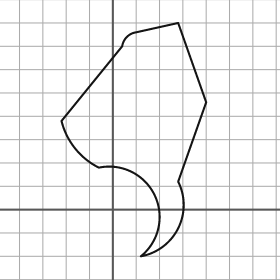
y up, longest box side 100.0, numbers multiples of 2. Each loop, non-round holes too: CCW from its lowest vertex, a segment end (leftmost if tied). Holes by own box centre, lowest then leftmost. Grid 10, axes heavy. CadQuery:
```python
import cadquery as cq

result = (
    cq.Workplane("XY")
    .moveTo(12.0, -20.0)
    .threePointArc((28.0, -8.0), (28.0, 12.0))
    .lineTo(40.0, 46.0)
    .lineTo(28.0, 80.0)
    .lineTo(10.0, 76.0)
    .threePointArc((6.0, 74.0), (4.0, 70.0))
    .lineTo(-22.0, 38.0)
    .threePointArc((-16.0, 26.0), (-6.0, 18.0))
    .threePointArc((18.0, 6.0), (12.0, -20.0))
    .close()
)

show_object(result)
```